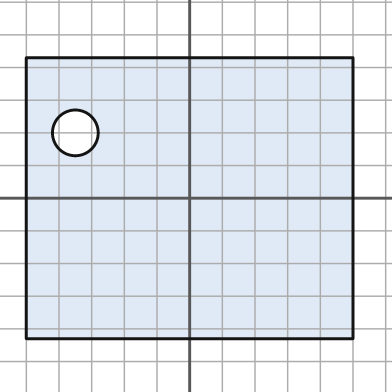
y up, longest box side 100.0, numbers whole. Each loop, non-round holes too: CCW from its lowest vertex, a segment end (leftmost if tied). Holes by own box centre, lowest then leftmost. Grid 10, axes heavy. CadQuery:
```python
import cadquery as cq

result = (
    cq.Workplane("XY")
    .moveTo(-50.0, -43.0)
    .lineTo(50.0, -43.0)
    .lineTo(50.0, 43.0)
    .lineTo(-50.0, 43.0)
    .close()
    .moveTo(-35.0, 20.0)
    .circle(7.0)
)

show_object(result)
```